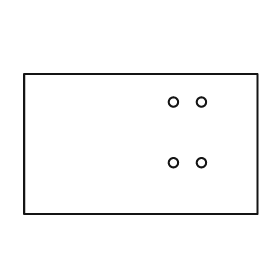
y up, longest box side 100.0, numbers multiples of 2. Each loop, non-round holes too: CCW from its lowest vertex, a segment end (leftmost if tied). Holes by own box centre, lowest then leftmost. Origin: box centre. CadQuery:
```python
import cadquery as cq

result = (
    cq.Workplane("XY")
    .moveTo(-50.0, -30.0)
    .lineTo(50.0, -30.0)
    .lineTo(50.0, 30.0)
    .lineTo(-50.0, 30.0)
    .close()
    .moveTo(14.0, -8.0)
    .circle(2.0)
    .moveTo(26.0, -8.0)
    .circle(2.0)
    .moveTo(14.0, 18.0)
    .circle(2.0)
    .moveTo(26.0, 18.0)
    .circle(2.0)
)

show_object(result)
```